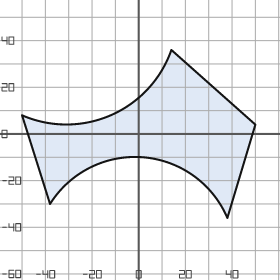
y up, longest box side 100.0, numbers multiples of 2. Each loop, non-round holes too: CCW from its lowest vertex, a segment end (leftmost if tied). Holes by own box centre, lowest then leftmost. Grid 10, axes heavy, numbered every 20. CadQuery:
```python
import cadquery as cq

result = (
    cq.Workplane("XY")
    .moveTo(38.0, -36.0)
    .lineTo(50.0, 4.0)
    .lineTo(14.0, 36.0)
    .threePointArc((-12.0, 8.0), (-50.0, 8.0))
    .lineTo(-38.0, -30.0)
    .threePointArc((2.0, -10.0), (38.0, -36.0))
    .close()
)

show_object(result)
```